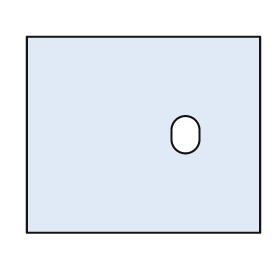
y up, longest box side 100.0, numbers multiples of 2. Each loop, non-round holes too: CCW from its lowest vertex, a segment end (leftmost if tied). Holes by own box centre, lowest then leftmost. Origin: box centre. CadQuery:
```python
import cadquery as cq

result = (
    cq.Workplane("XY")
    .moveTo(-50.0, -42.0)
    .lineTo(50.0, -42.0)
    .lineTo(50.0, 42.0)
    .lineTo(-50.0, 42.0)
    .close()
    .moveTo(12.0, -2.0)
    .threePointArc((18.0, -8.0), (24.0, -2.0))
    .lineTo(24.0, 2.0)
    .threePointArc((18.0, 8.0), (12.0, 2.0))
    .close()
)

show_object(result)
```